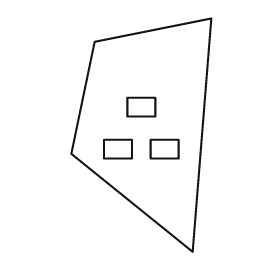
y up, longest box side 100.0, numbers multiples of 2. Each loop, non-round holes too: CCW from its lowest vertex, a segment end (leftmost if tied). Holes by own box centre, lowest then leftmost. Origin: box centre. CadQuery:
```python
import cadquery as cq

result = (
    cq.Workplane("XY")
    .moveTo(22.0, -50.0)
    .lineTo(30.0, 50.0)
    .lineTo(-20.0, 40.0)
    .lineTo(-30.0, -8.0)
    .close()
    .moveTo(-16.0, -10.0)
    .lineTo(-4.0, -10.0)
    .lineTo(-4.0, -2.0)
    .lineTo(-16.0, -2.0)
    .close()
    .moveTo(4.0, -10.0)
    .lineTo(16.0, -10.0)
    .lineTo(16.0, -2.0)
    .lineTo(4.0, -2.0)
    .close()
    .moveTo(-6.0, 8.0)
    .lineTo(6.0, 8.0)
    .lineTo(6.0, 16.0)
    .lineTo(-6.0, 16.0)
    .close()
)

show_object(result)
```